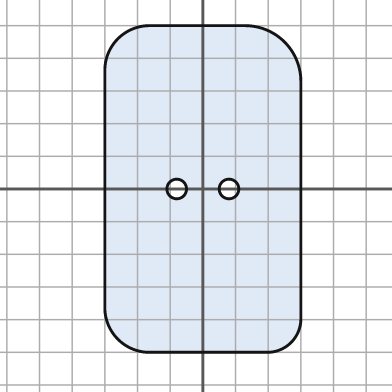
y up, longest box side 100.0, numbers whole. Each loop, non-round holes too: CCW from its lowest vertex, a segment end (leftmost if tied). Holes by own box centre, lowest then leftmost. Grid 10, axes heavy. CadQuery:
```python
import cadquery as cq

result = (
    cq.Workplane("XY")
    .moveTo(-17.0, -50.0)
    .lineTo(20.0, -50.0)
    .threePointArc((27.0, -47.0), (30.0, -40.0))
    .lineTo(30.0, 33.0)
    .threePointArc((25.0, 45.0), (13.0, 50.0))
    .lineTo(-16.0, 50.0)
    .threePointArc((-26.0, 46.0), (-30.0, 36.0))
    .lineTo(-30.0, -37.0)
    .threePointArc((-26.0, -46.0), (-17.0, -50.0))
    .close()
    .moveTo(-8.0, 0.0)
    .circle(3.0)
    .moveTo(8.0, 0.0)
    .circle(3.0)
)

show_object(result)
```